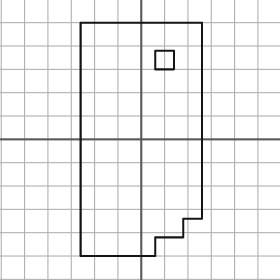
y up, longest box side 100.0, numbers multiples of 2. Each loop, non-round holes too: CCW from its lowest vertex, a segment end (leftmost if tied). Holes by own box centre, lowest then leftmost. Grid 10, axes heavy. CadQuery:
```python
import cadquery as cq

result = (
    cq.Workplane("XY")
    .moveTo(-26.0, -50.0)
    .lineTo(6.0, -50.0)
    .lineTo(6.0, -42.0)
    .lineTo(18.0, -42.0)
    .lineTo(18.0, -34.0)
    .lineTo(26.0, -34.0)
    .lineTo(26.0, 50.0)
    .lineTo(-26.0, 50.0)
    .close()
    .moveTo(6.0, 30.0)
    .lineTo(14.0, 30.0)
    .lineTo(14.0, 38.0)
    .lineTo(6.0, 38.0)
    .close()
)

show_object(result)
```